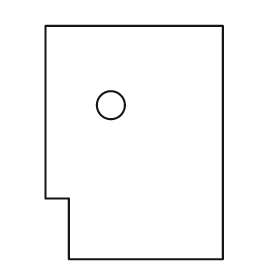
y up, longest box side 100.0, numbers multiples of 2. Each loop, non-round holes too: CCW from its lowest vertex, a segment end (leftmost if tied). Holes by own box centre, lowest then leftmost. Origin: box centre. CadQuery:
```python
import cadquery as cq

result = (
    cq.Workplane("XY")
    .moveTo(-28.0, -50.0)
    .lineTo(38.0, -50.0)
    .lineTo(38.0, 50.0)
    .lineTo(-38.0, 50.0)
    .lineTo(-38.0, -24.0)
    .lineTo(-28.0, -24.0)
    .close()
    .moveTo(-10.0, 16.0)
    .circle(6.0)
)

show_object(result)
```